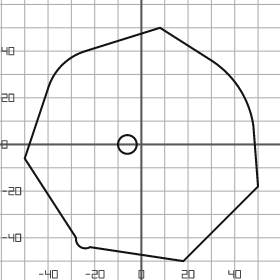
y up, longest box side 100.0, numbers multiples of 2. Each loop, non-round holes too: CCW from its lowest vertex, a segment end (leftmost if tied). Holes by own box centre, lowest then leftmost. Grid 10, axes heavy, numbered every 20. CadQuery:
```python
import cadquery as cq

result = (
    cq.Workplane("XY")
    .moveTo(18.0, -50.0)
    .lineTo(50.0, -18.0)
    .lineTo(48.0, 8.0)
    .threePointArc((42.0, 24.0), (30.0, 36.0))
    .lineTo(8.0, 50.0)
    .lineTo(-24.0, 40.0)
    .threePointArc((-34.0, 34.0), (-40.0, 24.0))
    .lineTo(-50.0, -6.0)
    .lineTo(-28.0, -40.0)
    .threePointArc((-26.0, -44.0), (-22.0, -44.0))
    .close()
    .moveTo(-6.0, 0.0)
    .circle(4.0)
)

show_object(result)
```